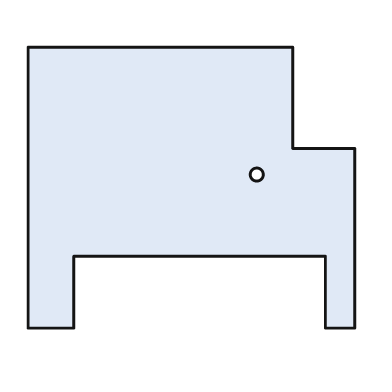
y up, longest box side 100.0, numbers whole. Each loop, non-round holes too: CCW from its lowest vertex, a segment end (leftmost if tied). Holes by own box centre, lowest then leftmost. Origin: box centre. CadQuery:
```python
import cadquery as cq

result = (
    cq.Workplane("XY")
    .moveTo(-50.0, -43.0)
    .lineTo(-36.0, -43.0)
    .lineTo(-36.0, -21.0)
    .lineTo(41.0, -21.0)
    .lineTo(41.0, -43.0)
    .lineTo(50.0, -43.0)
    .lineTo(50.0, 12.0)
    .lineTo(31.0, 12.0)
    .lineTo(31.0, 43.0)
    .lineTo(-50.0, 43.0)
    .close()
    .moveTo(20.0, 4.0)
    .circle(2.0)
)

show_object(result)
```